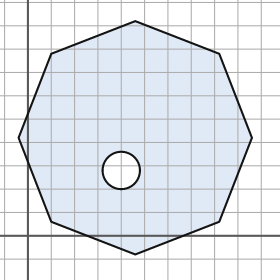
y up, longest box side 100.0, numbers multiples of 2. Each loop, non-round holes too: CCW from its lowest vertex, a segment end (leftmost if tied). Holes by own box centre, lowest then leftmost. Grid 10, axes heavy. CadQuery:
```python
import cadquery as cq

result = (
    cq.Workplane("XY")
    .moveTo(46.0, -8.0)
    .lineTo(82.0, 6.0)
    .lineTo(96.0, 42.0)
    .lineTo(82.0, 78.0)
    .lineTo(46.0, 92.0)
    .lineTo(10.0, 78.0)
    .lineTo(-4.0, 42.0)
    .lineTo(10.0, 6.0)
    .close()
    .moveTo(40.0, 28.0)
    .circle(8.0)
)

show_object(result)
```